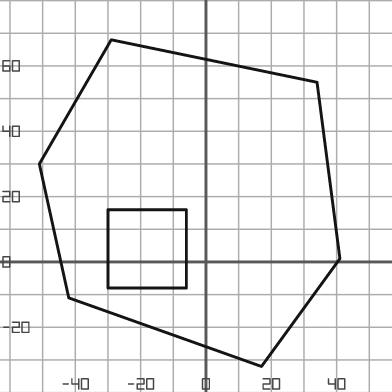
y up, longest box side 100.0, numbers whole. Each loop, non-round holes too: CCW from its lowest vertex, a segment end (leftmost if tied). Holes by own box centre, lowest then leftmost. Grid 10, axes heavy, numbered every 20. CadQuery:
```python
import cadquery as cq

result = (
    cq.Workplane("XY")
    .moveTo(17.0, -32.0)
    .lineTo(41.0, 1.0)
    .lineTo(34.0, 55.0)
    .lineTo(-29.0, 68.0)
    .lineTo(-51.0, 30.0)
    .lineTo(-42.0, -11.0)
    .close()
    .moveTo(-30.0, -8.0)
    .lineTo(-6.0, -8.0)
    .lineTo(-6.0, 16.0)
    .lineTo(-30.0, 16.0)
    .close()
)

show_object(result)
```